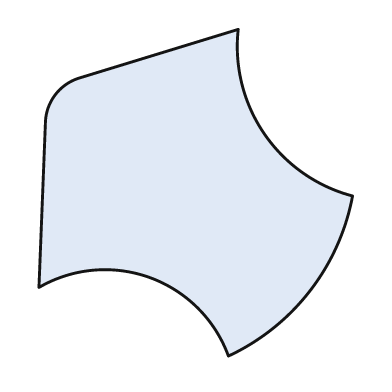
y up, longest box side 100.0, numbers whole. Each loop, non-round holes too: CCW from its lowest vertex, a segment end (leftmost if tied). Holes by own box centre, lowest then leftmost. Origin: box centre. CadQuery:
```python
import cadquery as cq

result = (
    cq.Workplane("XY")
    .moveTo(10.0, -50.0)
    .threePointArc((35.0, -30.0), (48.0, -1.0))
    .threePointArc((21.0, 18.0), (13.0, 50.0))
    .lineTo(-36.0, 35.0)
    .threePointArc((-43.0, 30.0), (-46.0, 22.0))
    .lineTo(-48.0, -29.0)
    .threePointArc((-14.0, -26.0), (10.0, -50.0))
    .close()
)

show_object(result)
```